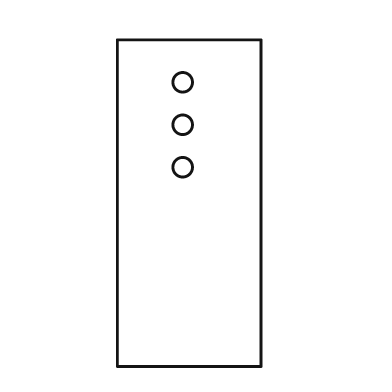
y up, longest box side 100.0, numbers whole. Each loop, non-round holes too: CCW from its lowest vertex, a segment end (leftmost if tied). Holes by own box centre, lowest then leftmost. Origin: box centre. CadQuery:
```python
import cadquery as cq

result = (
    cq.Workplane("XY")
    .moveTo(-22.0, -50.0)
    .lineTo(22.0, -50.0)
    .lineTo(22.0, 50.0)
    .lineTo(-22.0, 50.0)
    .close()
    .moveTo(-2.0, 11.0)
    .circle(3.0)
    .moveTo(-2.0, 24.0)
    .circle(3.0)
    .moveTo(-2.0, 37.0)
    .circle(3.0)
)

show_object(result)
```